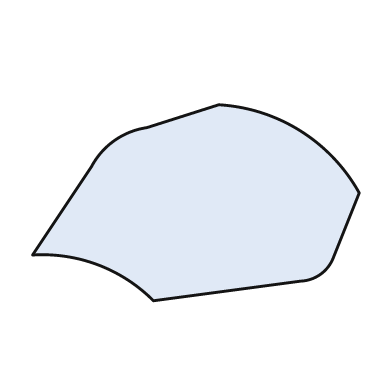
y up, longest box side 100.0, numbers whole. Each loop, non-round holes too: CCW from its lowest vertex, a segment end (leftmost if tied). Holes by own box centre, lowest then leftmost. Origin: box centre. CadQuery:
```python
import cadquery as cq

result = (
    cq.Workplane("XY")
    .moveTo(-13.0, -30.0)
    .lineTo(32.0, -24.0)
    .threePointArc((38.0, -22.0), (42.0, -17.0))
    .lineTo(50.0, 3.0)
    .threePointArc((32.0, 22.0), (7.0, 30.0))
    .lineTo(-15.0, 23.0)
    .threePointArc((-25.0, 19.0), (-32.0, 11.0))
    .lineTo(-50.0, -16.0)
    .threePointArc((-30.0, -19.0), (-13.0, -30.0))
    .close()
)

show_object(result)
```